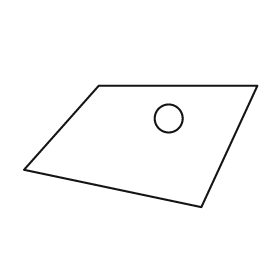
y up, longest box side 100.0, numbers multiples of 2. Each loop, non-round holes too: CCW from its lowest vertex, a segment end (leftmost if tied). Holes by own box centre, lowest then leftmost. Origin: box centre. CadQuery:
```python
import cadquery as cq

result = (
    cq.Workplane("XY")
    .moveTo(26.0, -26.0)
    .lineTo(50.0, 26.0)
    .lineTo(-18.0, 26.0)
    .lineTo(-50.0, -10.0)
    .close()
    .moveTo(12.0, 12.0)
    .circle(6.0)
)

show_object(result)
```